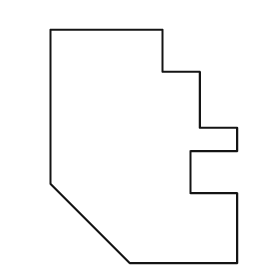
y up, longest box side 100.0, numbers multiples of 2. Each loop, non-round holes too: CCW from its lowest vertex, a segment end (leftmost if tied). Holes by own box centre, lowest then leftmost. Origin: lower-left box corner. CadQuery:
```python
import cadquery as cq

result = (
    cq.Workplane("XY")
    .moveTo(34.0, 0.0)
    .lineTo(80.0, 0.0)
    .lineTo(80.0, 30.0)
    .lineTo(60.0, 30.0)
    .lineTo(60.0, 48.0)
    .lineTo(80.0, 48.0)
    .lineTo(80.0, 58.0)
    .lineTo(64.0, 58.0)
    .lineTo(64.0, 82.0)
    .lineTo(48.0, 82.0)
    .lineTo(48.0, 100.0)
    .lineTo(0.0, 100.0)
    .lineTo(0.0, 34.0)
    .close()
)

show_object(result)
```